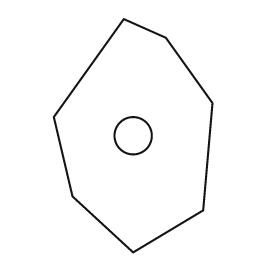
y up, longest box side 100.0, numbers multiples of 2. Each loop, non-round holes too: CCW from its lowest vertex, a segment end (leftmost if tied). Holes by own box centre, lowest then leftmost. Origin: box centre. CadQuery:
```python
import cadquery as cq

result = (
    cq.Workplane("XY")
    .moveTo(0.0, -50.0)
    .lineTo(30.0, -32.0)
    .lineTo(34.0, 14.0)
    .lineTo(14.0, 42.0)
    .lineTo(-4.0, 50.0)
    .lineTo(-34.0, 8.0)
    .lineTo(-26.0, -26.0)
    .close()
    .moveTo(0.0, 0.0)
    .circle(8.0)
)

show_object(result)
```